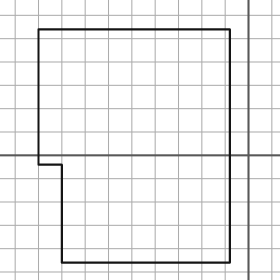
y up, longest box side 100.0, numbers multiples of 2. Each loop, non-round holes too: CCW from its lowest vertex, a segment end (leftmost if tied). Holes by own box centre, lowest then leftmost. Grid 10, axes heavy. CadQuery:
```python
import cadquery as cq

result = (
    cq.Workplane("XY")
    .moveTo(-80.0, -46.0)
    .lineTo(-8.0, -46.0)
    .lineTo(-8.0, 54.0)
    .lineTo(-90.0, 54.0)
    .lineTo(-90.0, -4.0)
    .lineTo(-80.0, -4.0)
    .close()
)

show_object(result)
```